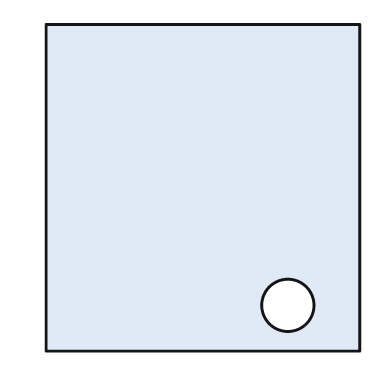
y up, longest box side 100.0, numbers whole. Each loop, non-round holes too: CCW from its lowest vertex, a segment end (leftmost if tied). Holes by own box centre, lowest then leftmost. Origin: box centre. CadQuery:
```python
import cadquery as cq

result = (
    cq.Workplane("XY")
    .moveTo(-48.0, -50.0)
    .lineTo(48.0, -50.0)
    .lineTo(48.0, 50.0)
    .lineTo(-48.0, 50.0)
    .close()
    .moveTo(26.0, -36.0)
    .circle(8.0)
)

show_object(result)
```